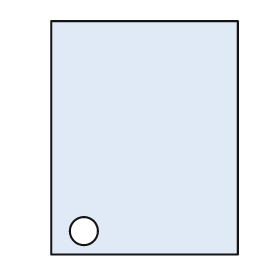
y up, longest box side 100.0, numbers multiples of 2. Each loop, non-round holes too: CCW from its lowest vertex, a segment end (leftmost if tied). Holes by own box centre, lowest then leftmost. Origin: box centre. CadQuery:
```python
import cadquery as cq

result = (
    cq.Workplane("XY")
    .moveTo(-40.0, -50.0)
    .lineTo(40.0, -50.0)
    .lineTo(40.0, 50.0)
    .lineTo(-40.0, 50.0)
    .close()
    .moveTo(-26.0, -40.0)
    .circle(6.0)
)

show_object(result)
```